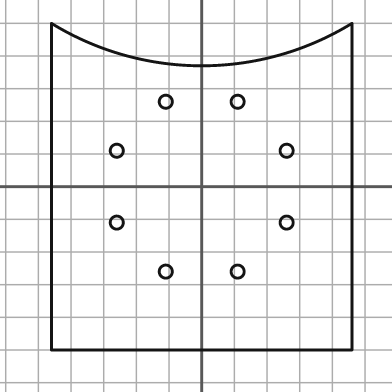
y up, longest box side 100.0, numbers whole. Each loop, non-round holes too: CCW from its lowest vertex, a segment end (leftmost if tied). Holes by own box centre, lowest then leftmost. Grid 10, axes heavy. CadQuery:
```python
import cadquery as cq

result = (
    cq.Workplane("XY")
    .moveTo(-46.0, -50.0)
    .lineTo(46.0, -50.0)
    .lineTo(46.0, 50.0)
    .threePointArc((0.0, 37.0), (-46.0, 50.0))
    .close()
    .moveTo(-11.0, -26.0)
    .circle(2.0)
    .moveTo(11.0, -26.0)
    .circle(2.0)
    .moveTo(-26.0, -11.0)
    .circle(2.0)
    .moveTo(26.0, -11.0)
    .circle(2.0)
    .moveTo(-26.0, 11.0)
    .circle(2.0)
    .moveTo(26.0, 11.0)
    .circle(2.0)
    .moveTo(-11.0, 26.0)
    .circle(2.0)
    .moveTo(11.0, 26.0)
    .circle(2.0)
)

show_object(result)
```